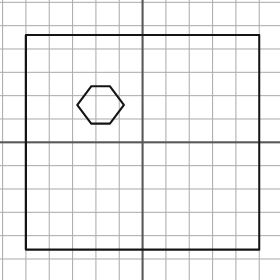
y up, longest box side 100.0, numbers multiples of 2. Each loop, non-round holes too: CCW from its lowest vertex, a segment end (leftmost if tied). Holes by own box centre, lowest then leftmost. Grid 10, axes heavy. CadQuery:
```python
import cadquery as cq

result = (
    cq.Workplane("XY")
    .moveTo(-50.0, -46.0)
    .lineTo(50.0, -46.0)
    .lineTo(50.0, 46.0)
    .lineTo(-50.0, 46.0)
    .close()
    .moveTo(-22.0, 8.0)
    .lineTo(-14.0, 8.0)
    .lineTo(-8.0, 16.0)
    .lineTo(-14.0, 24.0)
    .lineTo(-22.0, 24.0)
    .lineTo(-28.0, 16.0)
    .close()
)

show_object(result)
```